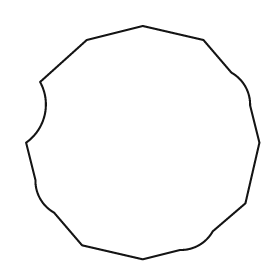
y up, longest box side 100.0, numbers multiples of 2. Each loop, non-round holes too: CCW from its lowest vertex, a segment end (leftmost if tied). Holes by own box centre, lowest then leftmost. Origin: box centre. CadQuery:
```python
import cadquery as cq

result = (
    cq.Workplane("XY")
    .moveTo(0.0, -50.0)
    .lineTo(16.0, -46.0)
    .threePointArc((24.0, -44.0), (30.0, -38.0))
    .lineTo(44.0, -26.0)
    .lineTo(50.0, 0.0)
    .lineTo(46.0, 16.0)
    .threePointArc((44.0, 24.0), (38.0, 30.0))
    .lineTo(26.0, 44.0)
    .lineTo(0.0, 50.0)
    .lineTo(-24.0, 44.0)
    .lineTo(-44.0, 26.0)
    .threePointArc((-42.0, 12.0), (-50.0, 0.0))
    .lineTo(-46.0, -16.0)
    .threePointArc((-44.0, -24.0), (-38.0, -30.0))
    .lineTo(-26.0, -44.0)
    .close()
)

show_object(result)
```